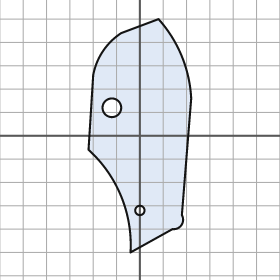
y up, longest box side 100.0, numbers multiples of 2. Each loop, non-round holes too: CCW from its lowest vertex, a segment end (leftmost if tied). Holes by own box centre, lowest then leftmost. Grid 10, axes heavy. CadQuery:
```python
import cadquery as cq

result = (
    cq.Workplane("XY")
    .moveTo(-4.0, -50.0)
    .lineTo(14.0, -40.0)
    .threePointArc((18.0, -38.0), (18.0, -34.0))
    .lineTo(22.0, 16.0)
    .threePointArc((18.0, 34.0), (8.0, 50.0))
    .lineTo(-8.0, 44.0)
    .threePointArc((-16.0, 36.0), (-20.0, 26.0))
    .lineTo(-22.0, -6.0)
    .threePointArc((-8.0, -26.0), (-4.0, -50.0))
    .close()
    .moveTo(0.0, -32.0)
    .circle(2.0)
    .moveTo(-12.0, 12.0)
    .circle(4.0)
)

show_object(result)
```